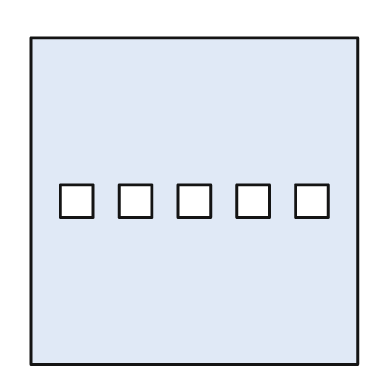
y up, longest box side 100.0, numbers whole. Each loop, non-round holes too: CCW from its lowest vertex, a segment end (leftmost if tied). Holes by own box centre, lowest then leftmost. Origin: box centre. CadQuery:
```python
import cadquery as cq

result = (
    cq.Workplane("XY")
    .moveTo(-50.0, -50.0)
    .lineTo(50.0, -50.0)
    .lineTo(50.0, 50.0)
    .lineTo(-50.0, 50.0)
    .close()
    .moveTo(-41.0, -5.0)
    .lineTo(-31.0, -5.0)
    .lineTo(-31.0, 5.0)
    .lineTo(-41.0, 5.0)
    .close()
    .moveTo(-23.0, -5.0)
    .lineTo(-13.0, -5.0)
    .lineTo(-13.0, 5.0)
    .lineTo(-23.0, 5.0)
    .close()
    .moveTo(-5.0, -5.0)
    .lineTo(5.0, -5.0)
    .lineTo(5.0, 5.0)
    .lineTo(-5.0, 5.0)
    .close()
    .moveTo(13.0, -5.0)
    .lineTo(23.0, -5.0)
    .lineTo(23.0, 5.0)
    .lineTo(13.0, 5.0)
    .close()
    .moveTo(31.0, -5.0)
    .lineTo(41.0, -5.0)
    .lineTo(41.0, 5.0)
    .lineTo(31.0, 5.0)
    .close()
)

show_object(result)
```